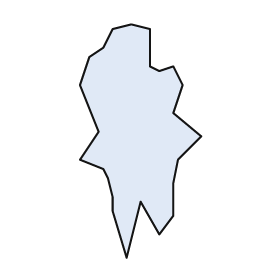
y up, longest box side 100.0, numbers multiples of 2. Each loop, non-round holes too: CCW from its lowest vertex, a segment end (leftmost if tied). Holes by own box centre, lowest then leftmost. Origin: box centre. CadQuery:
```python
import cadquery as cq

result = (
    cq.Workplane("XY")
    .moveTo(-6.0, -50.0)
    .lineTo(0.0, -26.0)
    .lineTo(8.0, -40.0)
    .lineTo(14.0, -32.0)
    .lineTo(14.0, -18.0)
    .lineTo(16.0, -8.0)
    .lineTo(26.0, 2.0)
    .lineTo(14.0, 12.0)
    .lineTo(18.0, 24.0)
    .lineTo(14.0, 32.0)
    .lineTo(8.0, 30.0)
    .lineTo(4.0, 32.0)
    .lineTo(4.0, 48.0)
    .lineTo(-4.0, 50.0)
    .lineTo(-12.0, 48.0)
    .lineTo(-16.0, 40.0)
    .lineTo(-22.0, 36.0)
    .lineTo(-26.0, 24.0)
    .lineTo(-18.0, 4.0)
    .lineTo(-26.0, -8.0)
    .lineTo(-16.0, -12.0)
    .lineTo(-14.0, -16.0)
    .lineTo(-12.0, -24.0)
    .lineTo(-12.0, -30.0)
    .close()
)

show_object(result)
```